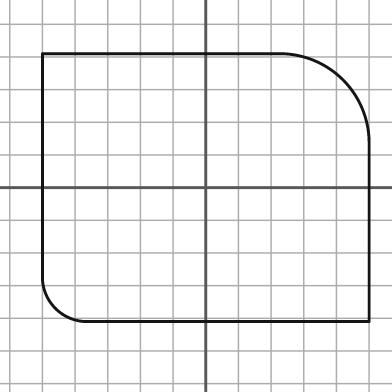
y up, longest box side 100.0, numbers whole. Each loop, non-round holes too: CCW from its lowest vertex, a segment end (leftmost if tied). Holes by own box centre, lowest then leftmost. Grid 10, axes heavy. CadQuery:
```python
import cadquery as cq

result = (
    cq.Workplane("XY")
    .moveTo(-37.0, -41.0)
    .lineTo(50.0, -41.0)
    .lineTo(50.0, 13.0)
    .threePointArc((42.0, 33.0), (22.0, 41.0))
    .lineTo(-50.0, 41.0)
    .lineTo(-50.0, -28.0)
    .threePointArc((-46.0, -37.0), (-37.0, -41.0))
    .close()
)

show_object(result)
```